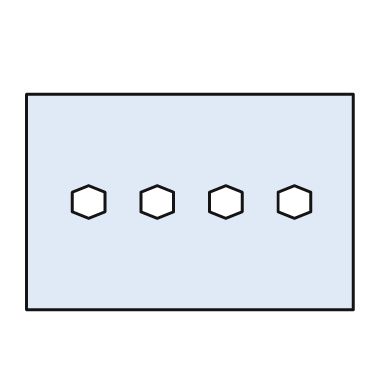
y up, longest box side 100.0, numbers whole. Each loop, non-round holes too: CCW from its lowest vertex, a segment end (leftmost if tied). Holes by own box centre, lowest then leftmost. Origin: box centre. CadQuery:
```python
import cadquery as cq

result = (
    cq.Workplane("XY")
    .moveTo(-50.0, -33.0)
    .lineTo(50.0, -33.0)
    .lineTo(50.0, 33.0)
    .lineTo(-50.0, 33.0)
    .close()
    .moveTo(-31.0, -5.0)
    .lineTo(-26.0, -3.0)
    .lineTo(-26.0, 3.0)
    .lineTo(-31.0, 5.0)
    .lineTo(-36.0, 3.0)
    .lineTo(-36.0, -3.0)
    .close()
    .moveTo(-10.0, -5.0)
    .lineTo(-5.0, -3.0)
    .lineTo(-5.0, 3.0)
    .lineTo(-10.0, 5.0)
    .lineTo(-15.0, 3.0)
    .lineTo(-15.0, -3.0)
    .close()
    .moveTo(11.0, -5.0)
    .lineTo(16.0, -3.0)
    .lineTo(16.0, 3.0)
    .lineTo(11.0, 5.0)
    .lineTo(6.0, 3.0)
    .lineTo(6.0, -3.0)
    .close()
    .moveTo(32.0, -5.0)
    .lineTo(37.0, -3.0)
    .lineTo(37.0, 3.0)
    .lineTo(32.0, 5.0)
    .lineTo(27.0, 3.0)
    .lineTo(27.0, -3.0)
    .close()
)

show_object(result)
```